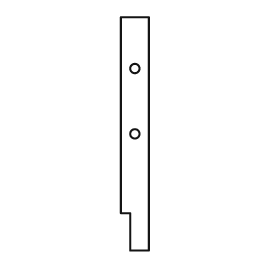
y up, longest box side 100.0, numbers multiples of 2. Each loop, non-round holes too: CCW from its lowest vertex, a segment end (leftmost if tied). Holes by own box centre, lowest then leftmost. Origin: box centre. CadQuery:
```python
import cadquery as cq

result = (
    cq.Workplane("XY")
    .moveTo(-2.0, -50.0)
    .lineTo(6.0, -50.0)
    .lineTo(6.0, 50.0)
    .lineTo(-6.0, 50.0)
    .lineTo(-6.0, -34.0)
    .lineTo(-2.0, -34.0)
    .close()
    .moveTo(0.0, 0.0)
    .circle(2.0)
    .moveTo(0.0, 28.0)
    .circle(2.0)
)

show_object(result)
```